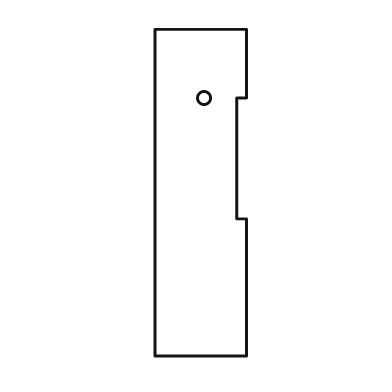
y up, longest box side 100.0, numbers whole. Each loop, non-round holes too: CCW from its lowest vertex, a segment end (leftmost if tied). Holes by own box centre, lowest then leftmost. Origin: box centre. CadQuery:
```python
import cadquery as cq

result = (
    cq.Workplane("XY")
    .moveTo(-14.0, -50.0)
    .lineTo(14.0, -50.0)
    .lineTo(14.0, -8.0)
    .lineTo(11.0, -8.0)
    .lineTo(11.0, 29.0)
    .lineTo(14.0, 29.0)
    .lineTo(14.0, 50.0)
    .lineTo(-14.0, 50.0)
    .close()
    .moveTo(1.0, 29.0)
    .circle(2.0)
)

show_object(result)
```